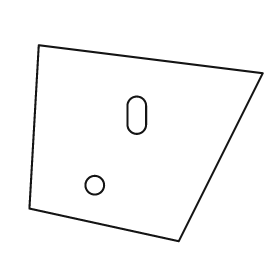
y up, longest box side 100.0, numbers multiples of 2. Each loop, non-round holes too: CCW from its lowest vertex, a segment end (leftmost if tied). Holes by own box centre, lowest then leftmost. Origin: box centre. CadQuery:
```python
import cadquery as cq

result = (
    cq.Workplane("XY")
    .moveTo(14.0, -42.0)
    .lineTo(50.0, 30.0)
    .lineTo(-46.0, 42.0)
    .lineTo(-50.0, -28.0)
    .close()
    .moveTo(-22.0, -18.0)
    .circle(4.0)
    .moveTo(-8.0, 8.0)
    .threePointArc((-4.0, 4.0), (0.0, 8.0))
    .lineTo(0.0, 16.0)
    .threePointArc((-4.0, 20.0), (-8.0, 16.0))
    .close()
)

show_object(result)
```